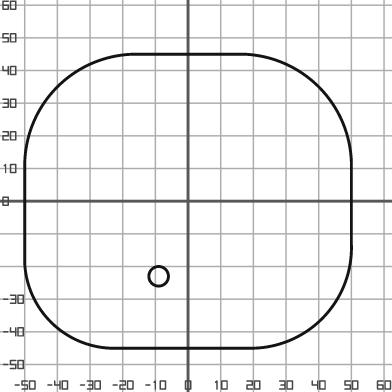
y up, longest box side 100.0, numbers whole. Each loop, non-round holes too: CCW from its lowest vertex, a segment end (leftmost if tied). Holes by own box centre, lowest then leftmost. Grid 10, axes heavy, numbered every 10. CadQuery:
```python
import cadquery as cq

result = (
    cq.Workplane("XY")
    .moveTo(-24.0, -45.0)
    .lineTo(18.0, -45.0)
    .threePointArc((41.0, -36.0), (50.0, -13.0))
    .lineTo(50.0, 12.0)
    .threePointArc((40.0, 35.0), (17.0, 45.0))
    .lineTo(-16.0, 45.0)
    .threePointArc((-40.0, 35.0), (-50.0, 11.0))
    .lineTo(-50.0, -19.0)
    .threePointArc((-42.0, -37.0), (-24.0, -45.0))
    .close()
    .moveTo(-9.0, -23.0)
    .circle(3.0)
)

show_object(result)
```